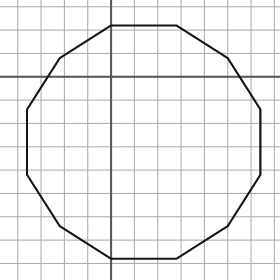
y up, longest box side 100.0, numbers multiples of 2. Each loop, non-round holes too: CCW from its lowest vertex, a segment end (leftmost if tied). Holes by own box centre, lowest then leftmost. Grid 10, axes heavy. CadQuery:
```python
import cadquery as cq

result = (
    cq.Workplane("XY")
    .moveTo(0.0, -78.0)
    .lineTo(28.0, -78.0)
    .lineTo(50.0, -64.0)
    .lineTo(64.0, -42.0)
    .lineTo(64.0, -14.0)
    .lineTo(50.0, 8.0)
    .lineTo(28.0, 22.0)
    .lineTo(0.0, 22.0)
    .lineTo(-22.0, 8.0)
    .lineTo(-36.0, -14.0)
    .lineTo(-36.0, -42.0)
    .lineTo(-22.0, -64.0)
    .close()
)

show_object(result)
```